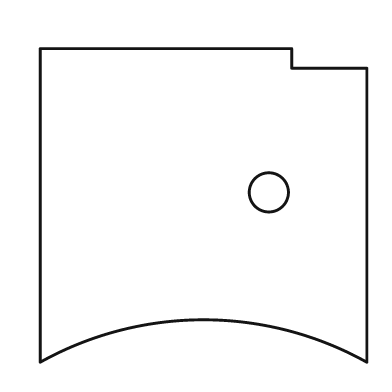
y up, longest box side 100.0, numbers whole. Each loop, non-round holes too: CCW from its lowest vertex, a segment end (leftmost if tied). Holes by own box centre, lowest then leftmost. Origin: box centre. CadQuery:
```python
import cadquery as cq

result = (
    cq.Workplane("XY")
    .moveTo(-50.0, -48.0)
    .threePointArc((0.0, -35.0), (50.0, -48.0))
    .lineTo(50.0, 42.0)
    .lineTo(27.0, 42.0)
    .lineTo(27.0, 48.0)
    .lineTo(-50.0, 48.0)
    .close()
    .moveTo(20.0, 4.0)
    .circle(6.0)
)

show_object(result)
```